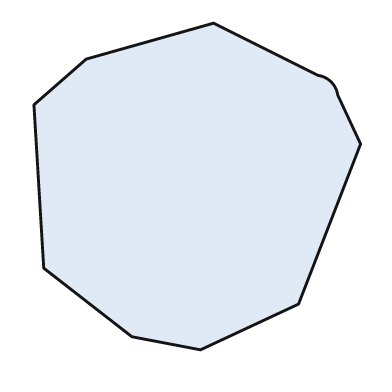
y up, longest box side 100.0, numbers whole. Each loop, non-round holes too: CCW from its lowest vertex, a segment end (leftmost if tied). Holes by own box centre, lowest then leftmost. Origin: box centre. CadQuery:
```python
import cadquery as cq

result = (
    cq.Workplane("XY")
    .moveTo(1.0, -50.0)
    .lineTo(31.0, -36.0)
    .lineTo(50.0, 13.0)
    .lineTo(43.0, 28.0)
    .threePointArc((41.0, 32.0), (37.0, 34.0))
    .lineTo(5.0, 50.0)
    .lineTo(-34.0, 39.0)
    .lineTo(-50.0, 25.0)
    .lineTo(-47.0, -25.0)
    .lineTo(-20.0, -46.0)
    .close()
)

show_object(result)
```